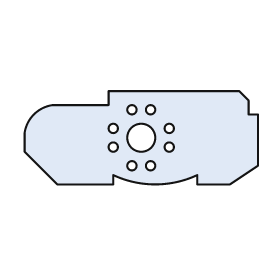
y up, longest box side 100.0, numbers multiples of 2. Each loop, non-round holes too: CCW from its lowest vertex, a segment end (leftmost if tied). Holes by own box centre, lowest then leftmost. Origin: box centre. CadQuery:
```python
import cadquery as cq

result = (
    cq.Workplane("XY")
    .moveTo(-36.0, -20.0)
    .lineTo(-12.0, -20.0)
    .lineTo(-12.0, -16.0)
    .threePointArc((6.0, -20.0), (24.0, -16.0))
    .lineTo(24.0, -20.0)
    .lineTo(38.0, -20.0)
    .lineTo(50.0, -12.0)
    .lineTo(50.0, 10.0)
    .lineTo(46.0, 10.0)
    .lineTo(46.0, 16.0)
    .lineTo(42.0, 20.0)
    .lineTo(-14.0, 20.0)
    .lineTo(-14.0, 14.0)
    .lineTo(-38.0, 14.0)
    .threePointArc((-46.0, 10.0), (-50.0, 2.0))
    .lineTo(-50.0, -6.0)
    .close()
    .moveTo(-4.0, -12.0)
    .circle(2.0)
    .moveTo(4.0, -12.0)
    .circle(2.0)
    .moveTo(-12.0, -4.0)
    .circle(2.0)
    .moveTo(12.0, -4.0)
    .circle(2.0)
    .moveTo(0.0, 0.0)
    .circle(6.0)
    .moveTo(-12.0, 4.0)
    .circle(2.0)
    .moveTo(12.0, 4.0)
    .circle(2.0)
    .moveTo(-4.0, 12.0)
    .circle(2.0)
    .moveTo(4.0, 12.0)
    .circle(2.0)
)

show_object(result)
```